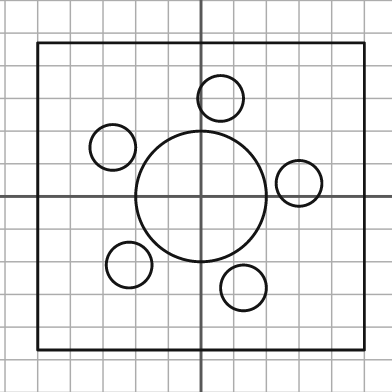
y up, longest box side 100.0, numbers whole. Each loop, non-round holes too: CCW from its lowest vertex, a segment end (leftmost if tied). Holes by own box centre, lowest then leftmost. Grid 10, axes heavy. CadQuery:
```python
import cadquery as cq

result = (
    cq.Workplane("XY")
    .moveTo(-50.0, -47.0)
    .lineTo(50.0, -47.0)
    .lineTo(50.0, 47.0)
    .lineTo(-50.0, 47.0)
    .close()
    .moveTo(13.0, -28.0)
    .circle(7.0)
    .moveTo(-22.0, -21.0)
    .circle(7.0)
    .moveTo(0.0, 0.0)
    .circle(20.0)
    .moveTo(30.0, 4.0)
    .circle(7.0)
    .moveTo(-27.0, 15.0)
    .circle(7.0)
    .moveTo(6.0, 30.0)
    .circle(7.0)
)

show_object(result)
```